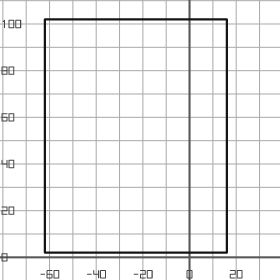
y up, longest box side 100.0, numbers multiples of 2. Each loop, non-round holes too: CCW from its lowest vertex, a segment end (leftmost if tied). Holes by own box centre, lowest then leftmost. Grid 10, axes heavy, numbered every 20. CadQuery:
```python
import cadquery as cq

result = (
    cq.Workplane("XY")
    .moveTo(-62.0, 2.0)
    .lineTo(16.0, 2.0)
    .lineTo(16.0, 102.0)
    .lineTo(-62.0, 102.0)
    .close()
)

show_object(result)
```